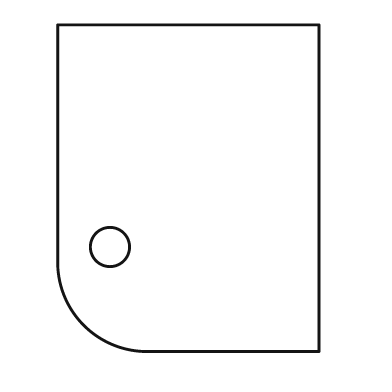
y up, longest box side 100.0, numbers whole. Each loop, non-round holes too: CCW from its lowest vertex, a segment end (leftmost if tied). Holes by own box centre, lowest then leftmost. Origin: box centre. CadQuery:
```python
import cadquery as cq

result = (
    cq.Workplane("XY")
    .moveTo(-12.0, -50.0)
    .lineTo(40.0, -50.0)
    .lineTo(40.0, 50.0)
    .lineTo(-40.0, 50.0)
    .lineTo(-40.0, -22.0)
    .threePointArc((-32.0, -42.0), (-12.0, -50.0))
    .close()
    .moveTo(-24.0, -18.0)
    .circle(6.0)
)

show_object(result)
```